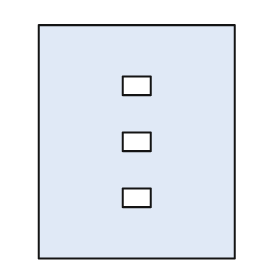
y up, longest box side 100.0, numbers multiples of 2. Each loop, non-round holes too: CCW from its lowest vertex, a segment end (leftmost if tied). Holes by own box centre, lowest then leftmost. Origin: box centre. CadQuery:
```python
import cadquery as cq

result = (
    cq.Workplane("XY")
    .moveTo(-42.0, -50.0)
    .lineTo(42.0, -50.0)
    .lineTo(42.0, 50.0)
    .lineTo(-42.0, 50.0)
    .close()
    .moveTo(-6.0, -28.0)
    .lineTo(6.0, -28.0)
    .lineTo(6.0, -20.0)
    .lineTo(-6.0, -20.0)
    .close()
    .moveTo(-6.0, -4.0)
    .lineTo(6.0, -4.0)
    .lineTo(6.0, 4.0)
    .lineTo(-6.0, 4.0)
    .close()
    .moveTo(-6.0, 20.0)
    .lineTo(6.0, 20.0)
    .lineTo(6.0, 28.0)
    .lineTo(-6.0, 28.0)
    .close()
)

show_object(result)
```